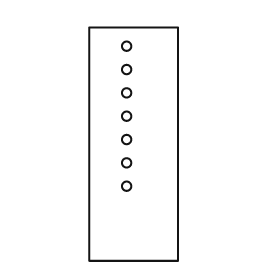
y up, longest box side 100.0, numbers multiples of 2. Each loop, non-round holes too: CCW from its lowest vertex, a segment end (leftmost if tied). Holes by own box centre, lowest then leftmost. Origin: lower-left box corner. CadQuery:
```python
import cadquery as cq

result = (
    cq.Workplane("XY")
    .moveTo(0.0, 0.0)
    .lineTo(38.0, 0.0)
    .lineTo(38.0, 100.0)
    .lineTo(0.0, 100.0)
    .close()
    .moveTo(16.0, 32.0)
    .circle(2.0)
    .moveTo(16.0, 42.0)
    .circle(2.0)
    .moveTo(16.0, 52.0)
    .circle(2.0)
    .moveTo(16.0, 62.0)
    .circle(2.0)
    .moveTo(16.0, 72.0)
    .circle(2.0)
    .moveTo(16.0, 82.0)
    .circle(2.0)
    .moveTo(16.0, 92.0)
    .circle(2.0)
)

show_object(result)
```